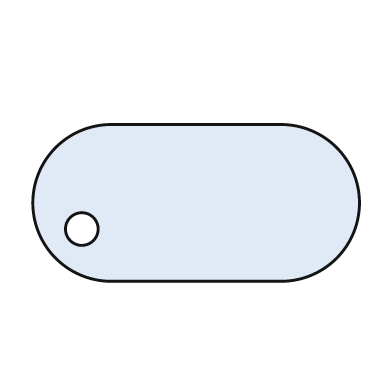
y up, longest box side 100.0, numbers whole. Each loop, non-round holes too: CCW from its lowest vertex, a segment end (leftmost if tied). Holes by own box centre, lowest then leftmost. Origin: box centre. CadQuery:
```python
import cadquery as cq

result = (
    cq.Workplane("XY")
    .moveTo(-26.0, -24.0)
    .lineTo(26.0, -24.0)
    .threePointArc((50.0, 0.0), (26.0, 24.0))
    .lineTo(-26.0, 24.0)
    .threePointArc((-50.0, 0.0), (-26.0, -24.0))
    .close()
    .moveTo(-35.0, -8.0)
    .circle(5.0)
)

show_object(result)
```